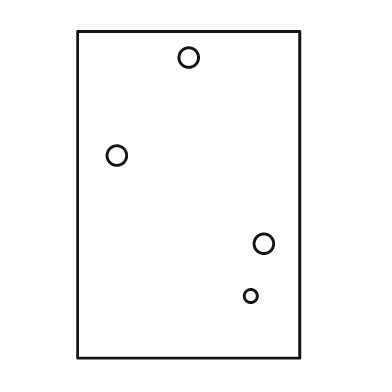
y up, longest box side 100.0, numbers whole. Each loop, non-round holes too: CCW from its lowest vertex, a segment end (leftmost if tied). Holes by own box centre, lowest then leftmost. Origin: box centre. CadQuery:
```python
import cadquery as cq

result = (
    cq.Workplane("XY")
    .moveTo(-34.0, -50.0)
    .lineTo(34.0, -50.0)
    .lineTo(34.0, 50.0)
    .lineTo(-34.0, 50.0)
    .close()
    .moveTo(19.0, -31.0)
    .circle(2.0)
    .moveTo(23.0, -15.0)
    .circle(3.0)
    .moveTo(-22.0, 12.0)
    .circle(3.0)
    .moveTo(0.0, 42.0)
    .circle(3.0)
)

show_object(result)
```